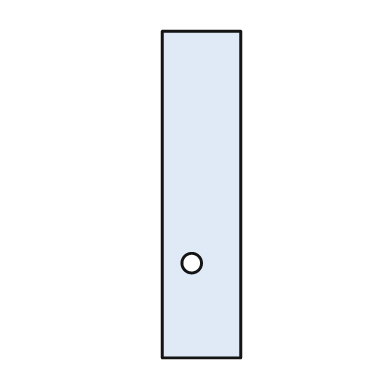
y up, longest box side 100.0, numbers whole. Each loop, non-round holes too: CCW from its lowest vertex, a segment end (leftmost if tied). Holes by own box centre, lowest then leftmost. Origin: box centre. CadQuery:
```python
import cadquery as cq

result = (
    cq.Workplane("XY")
    .moveTo(-12.0, -50.0)
    .lineTo(12.0, -50.0)
    .lineTo(12.0, 50.0)
    .lineTo(-12.0, 50.0)
    .close()
    .moveTo(-3.0, -21.0)
    .circle(3.0)
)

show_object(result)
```